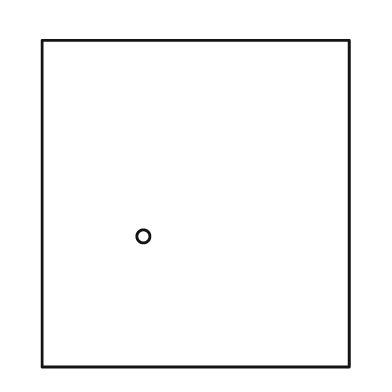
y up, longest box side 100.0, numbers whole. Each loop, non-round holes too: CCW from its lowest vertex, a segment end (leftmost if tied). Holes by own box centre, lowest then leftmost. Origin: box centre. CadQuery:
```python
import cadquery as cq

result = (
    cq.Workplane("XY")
    .moveTo(-47.0, -50.0)
    .lineTo(47.0, -50.0)
    .lineTo(47.0, 50.0)
    .lineTo(-47.0, 50.0)
    .close()
    .moveTo(-16.0, -10.0)
    .circle(2.0)
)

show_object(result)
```